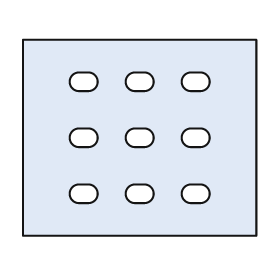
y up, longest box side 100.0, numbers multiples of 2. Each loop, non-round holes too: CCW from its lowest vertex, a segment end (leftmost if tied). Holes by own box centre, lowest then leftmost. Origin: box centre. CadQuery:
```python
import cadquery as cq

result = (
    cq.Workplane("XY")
    .moveTo(-50.0, -42.0)
    .lineTo(50.0, -42.0)
    .lineTo(50.0, 42.0)
    .lineTo(-50.0, 42.0)
    .close()
    .moveTo(-26.0, -28.0)
    .lineTo(-22.0, -28.0)
    .threePointArc((-18.0, -24.0), (-22.0, -20.0))
    .lineTo(-26.0, -20.0)
    .threePointArc((-30.0, -24.0), (-26.0, -28.0))
    .close()
    .moveTo(-2.0, -28.0)
    .lineTo(2.0, -28.0)
    .threePointArc((6.0, -24.0), (2.0, -20.0))
    .lineTo(-2.0, -20.0)
    .threePointArc((-6.0, -24.0), (-2.0, -28.0))
    .close()
    .moveTo(22.0, -28.0)
    .lineTo(26.0, -28.0)
    .threePointArc((30.0, -24.0), (26.0, -20.0))
    .lineTo(22.0, -20.0)
    .threePointArc((18.0, -24.0), (22.0, -28.0))
    .close()
    .moveTo(-26.0, -4.0)
    .lineTo(-22.0, -4.0)
    .threePointArc((-18.0, 0.0), (-22.0, 4.0))
    .lineTo(-26.0, 4.0)
    .threePointArc((-30.0, 0.0), (-26.0, -4.0))
    .close()
    .moveTo(-2.0, -4.0)
    .lineTo(2.0, -4.0)
    .threePointArc((6.0, 0.0), (2.0, 4.0))
    .lineTo(-2.0, 4.0)
    .threePointArc((-6.0, 0.0), (-2.0, -4.0))
    .close()
    .moveTo(22.0, -4.0)
    .lineTo(26.0, -4.0)
    .threePointArc((30.0, 0.0), (26.0, 4.0))
    .lineTo(22.0, 4.0)
    .threePointArc((18.0, 0.0), (22.0, -4.0))
    .close()
    .moveTo(-26.0, 20.0)
    .lineTo(-22.0, 20.0)
    .threePointArc((-18.0, 24.0), (-22.0, 28.0))
    .lineTo(-26.0, 28.0)
    .threePointArc((-30.0, 24.0), (-26.0, 20.0))
    .close()
    .moveTo(-2.0, 20.0)
    .lineTo(2.0, 20.0)
    .threePointArc((6.0, 24.0), (2.0, 28.0))
    .lineTo(-2.0, 28.0)
    .threePointArc((-6.0, 24.0), (-2.0, 20.0))
    .close()
    .moveTo(22.0, 20.0)
    .lineTo(26.0, 20.0)
    .threePointArc((30.0, 24.0), (26.0, 28.0))
    .lineTo(22.0, 28.0)
    .threePointArc((18.0, 24.0), (22.0, 20.0))
    .close()
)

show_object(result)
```